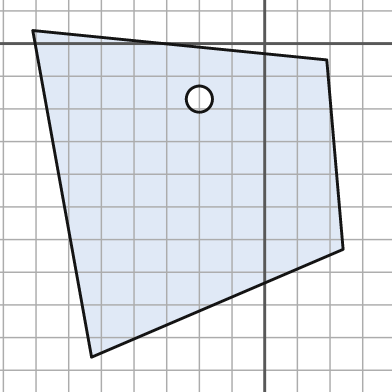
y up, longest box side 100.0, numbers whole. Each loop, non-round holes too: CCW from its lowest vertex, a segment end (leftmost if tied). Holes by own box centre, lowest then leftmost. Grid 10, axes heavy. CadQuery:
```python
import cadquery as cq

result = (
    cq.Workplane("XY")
    .moveTo(-53.0, -96.0)
    .lineTo(24.0, -63.0)
    .lineTo(19.0, -5.0)
    .lineTo(-71.0, 4.0)
    .close()
    .moveTo(-20.0, -17.0)
    .circle(4.0)
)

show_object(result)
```